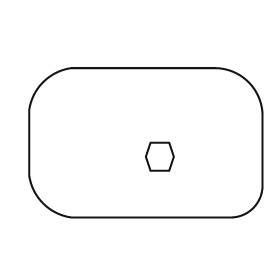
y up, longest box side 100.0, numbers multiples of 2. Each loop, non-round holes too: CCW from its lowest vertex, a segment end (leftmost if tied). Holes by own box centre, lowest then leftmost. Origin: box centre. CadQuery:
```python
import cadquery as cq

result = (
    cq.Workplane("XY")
    .moveTo(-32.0, -32.0)
    .lineTo(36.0, -32.0)
    .threePointArc((46.0, -28.0), (50.0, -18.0))
    .lineTo(50.0, 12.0)
    .threePointArc((44.0, 26.0), (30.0, 32.0))
    .lineTo(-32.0, 32.0)
    .threePointArc((-44.0, 26.0), (-50.0, 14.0))
    .lineTo(-50.0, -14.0)
    .threePointArc((-44.0, -26.0), (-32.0, -32.0))
    .close()
    .moveTo(2.0, -12.0)
    .lineTo(10.0, -12.0)
    .lineTo(12.0, -6.0)
    .lineTo(10.0, 0.0)
    .lineTo(2.0, 0.0)
    .lineTo(0.0, -6.0)
    .close()
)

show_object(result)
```